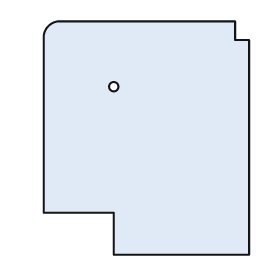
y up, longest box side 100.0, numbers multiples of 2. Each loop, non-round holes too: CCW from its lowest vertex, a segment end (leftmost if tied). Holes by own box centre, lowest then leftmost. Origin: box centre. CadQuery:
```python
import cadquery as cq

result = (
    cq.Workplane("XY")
    .moveTo(-14.0, -50.0)
    .lineTo(44.0, -50.0)
    .lineTo(44.0, 42.0)
    .lineTo(38.0, 42.0)
    .lineTo(38.0, 50.0)
    .lineTo(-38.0, 50.0)
    .threePointArc((-42.0, 48.0), (-44.0, 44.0))
    .lineTo(-44.0, -32.0)
    .lineTo(-14.0, -32.0)
    .close()
    .moveTo(-14.0, 22.0)
    .circle(2.0)
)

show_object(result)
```